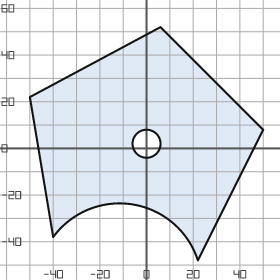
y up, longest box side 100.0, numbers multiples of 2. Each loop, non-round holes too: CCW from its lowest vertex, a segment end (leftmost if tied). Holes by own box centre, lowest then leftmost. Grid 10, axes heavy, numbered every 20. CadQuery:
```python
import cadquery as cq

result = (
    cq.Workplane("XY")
    .moveTo(22.0, -48.0)
    .lineTo(50.0, 8.0)
    .lineTo(6.0, 52.0)
    .lineTo(-50.0, 22.0)
    .lineTo(-40.0, -38.0)
    .threePointArc((-6.0, -24.0), (22.0, -48.0))
    .close()
    .moveTo(0.0, 2.0)
    .circle(6.0)
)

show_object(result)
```